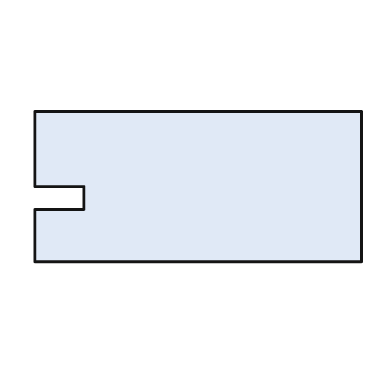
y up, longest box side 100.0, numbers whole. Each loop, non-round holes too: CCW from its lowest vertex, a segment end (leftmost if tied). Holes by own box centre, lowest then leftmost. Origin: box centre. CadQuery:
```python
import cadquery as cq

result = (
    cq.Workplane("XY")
    .moveTo(-50.0, -23.0)
    .lineTo(50.0, -23.0)
    .lineTo(50.0, 23.0)
    .lineTo(-50.0, 23.0)
    .lineTo(-50.0, 0.0)
    .lineTo(-35.0, 0.0)
    .lineTo(-35.0, -7.0)
    .lineTo(-50.0, -7.0)
    .close()
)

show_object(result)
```